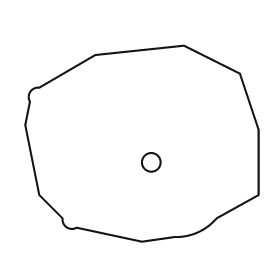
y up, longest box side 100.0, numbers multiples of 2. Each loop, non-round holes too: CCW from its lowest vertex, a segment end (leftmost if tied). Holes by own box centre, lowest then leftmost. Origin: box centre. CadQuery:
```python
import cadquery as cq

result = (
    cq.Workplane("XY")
    .moveTo(0.0, -42.0)
    .lineTo(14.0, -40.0)
    .threePointArc((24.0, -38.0), (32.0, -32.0))
    .lineTo(50.0, -22.0)
    .lineTo(50.0, 6.0)
    .lineTo(42.0, 30.0)
    .lineTo(18.0, 42.0)
    .lineTo(-20.0, 38.0)
    .lineTo(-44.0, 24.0)
    .threePointArc((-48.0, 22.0), (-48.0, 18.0))
    .lineTo(-50.0, 8.0)
    .lineTo(-44.0, -22.0)
    .lineTo(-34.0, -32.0)
    .threePointArc((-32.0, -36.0), (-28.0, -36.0))
    .close()
    .moveTo(4.0, -8.0)
    .circle(4.0)
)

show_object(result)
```